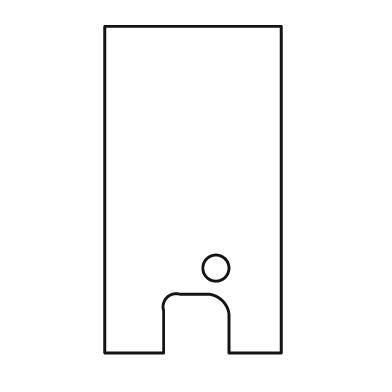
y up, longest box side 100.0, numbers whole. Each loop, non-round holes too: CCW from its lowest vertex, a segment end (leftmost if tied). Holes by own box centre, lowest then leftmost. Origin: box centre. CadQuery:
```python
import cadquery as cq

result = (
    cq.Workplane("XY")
    .moveTo(-27.0, -50.0)
    .lineTo(-9.0, -50.0)
    .lineTo(-9.0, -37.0)
    .threePointArc((-8.0, -33.0), (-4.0, -32.0))
    .lineTo(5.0, -32.0)
    .threePointArc((9.0, -34.0), (11.0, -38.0))
    .lineTo(11.0, -50.0)
    .lineTo(27.0, -50.0)
    .lineTo(27.0, 50.0)
    .lineTo(-27.0, 50.0)
    .close()
    .moveTo(7.0, -24.0)
    .circle(4.0)
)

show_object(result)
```